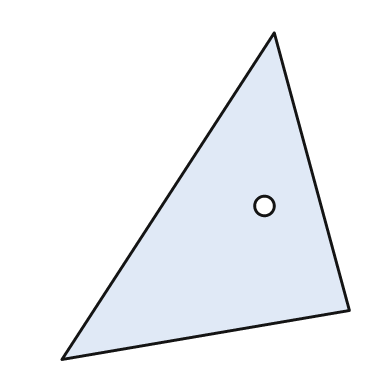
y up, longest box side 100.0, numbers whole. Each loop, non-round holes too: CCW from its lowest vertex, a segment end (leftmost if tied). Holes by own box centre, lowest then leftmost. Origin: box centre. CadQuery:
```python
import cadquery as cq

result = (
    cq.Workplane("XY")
    .moveTo(-44.0, -50.0)
    .lineTo(44.0, -35.0)
    .lineTo(21.0, 50.0)
    .close()
    .moveTo(18.0, -3.0)
    .circle(3.0)
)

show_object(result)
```